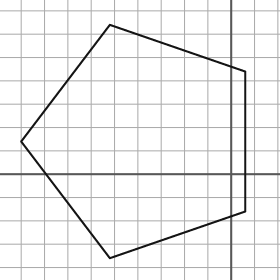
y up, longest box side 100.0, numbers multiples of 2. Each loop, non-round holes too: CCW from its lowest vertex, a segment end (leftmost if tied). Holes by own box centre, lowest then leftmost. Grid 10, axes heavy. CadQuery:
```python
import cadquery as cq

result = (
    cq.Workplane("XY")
    .moveTo(-52.0, -36.0)
    .lineTo(6.0, -16.0)
    .lineTo(6.0, 44.0)
    .lineTo(-52.0, 64.0)
    .lineTo(-90.0, 14.0)
    .close()
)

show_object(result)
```